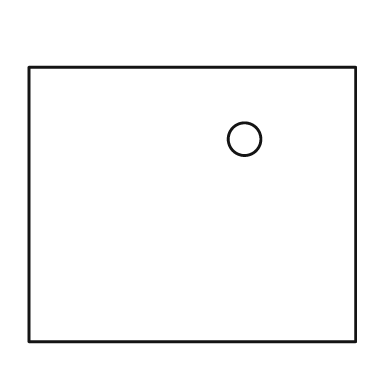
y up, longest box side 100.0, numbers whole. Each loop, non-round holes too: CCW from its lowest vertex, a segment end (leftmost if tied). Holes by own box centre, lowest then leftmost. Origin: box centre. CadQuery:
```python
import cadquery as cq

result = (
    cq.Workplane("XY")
    .moveTo(-50.0, -42.0)
    .lineTo(50.0, -42.0)
    .lineTo(50.0, 42.0)
    .lineTo(-50.0, 42.0)
    .close()
    .moveTo(16.0, 20.0)
    .circle(5.0)
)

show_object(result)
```